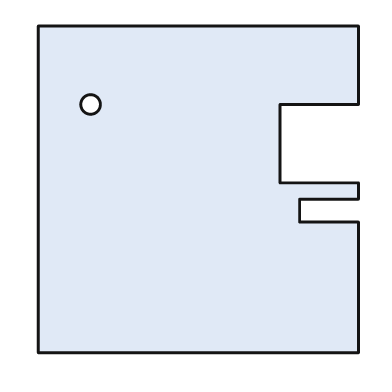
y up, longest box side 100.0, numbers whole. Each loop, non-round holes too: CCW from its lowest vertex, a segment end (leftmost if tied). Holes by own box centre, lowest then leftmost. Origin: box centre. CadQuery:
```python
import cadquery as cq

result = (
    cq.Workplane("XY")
    .moveTo(-49.0, -50.0)
    .lineTo(49.0, -50.0)
    .lineTo(49.0, -10.0)
    .lineTo(31.0, -10.0)
    .lineTo(31.0, -3.0)
    .lineTo(49.0, -3.0)
    .lineTo(49.0, 2.0)
    .lineTo(25.0, 2.0)
    .lineTo(25.0, 26.0)
    .lineTo(49.0, 26.0)
    .lineTo(49.0, 50.0)
    .lineTo(-49.0, 50.0)
    .close()
    .moveTo(-33.0, 26.0)
    .circle(3.0)
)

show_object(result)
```